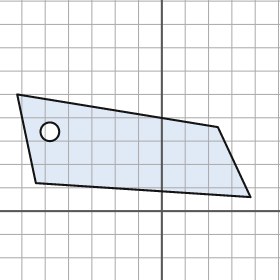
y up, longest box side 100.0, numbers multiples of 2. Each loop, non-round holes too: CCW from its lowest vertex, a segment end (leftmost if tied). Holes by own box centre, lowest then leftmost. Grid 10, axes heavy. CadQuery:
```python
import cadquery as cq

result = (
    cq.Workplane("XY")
    .moveTo(38.0, 6.0)
    .lineTo(24.0, 36.0)
    .lineTo(-62.0, 50.0)
    .lineTo(-54.0, 12.0)
    .close()
    .moveTo(-48.0, 34.0)
    .circle(4.0)
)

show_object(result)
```